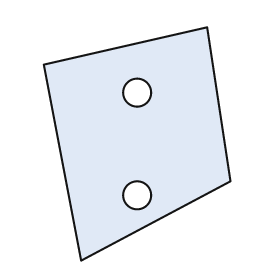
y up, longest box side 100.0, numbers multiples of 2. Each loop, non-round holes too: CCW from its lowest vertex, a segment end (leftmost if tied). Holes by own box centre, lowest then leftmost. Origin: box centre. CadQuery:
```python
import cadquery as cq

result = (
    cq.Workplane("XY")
    .moveTo(-24.0, -50.0)
    .lineTo(40.0, -16.0)
    .lineTo(30.0, 50.0)
    .lineTo(-40.0, 34.0)
    .close()
    .moveTo(0.0, -22.0)
    .circle(6.0)
    .moveTo(0.0, 22.0)
    .circle(6.0)
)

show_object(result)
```